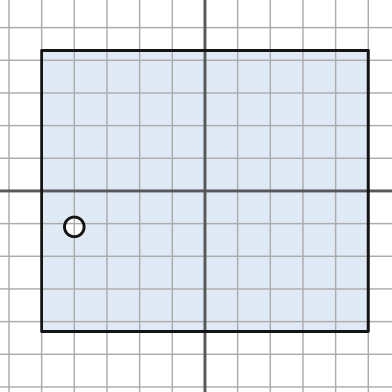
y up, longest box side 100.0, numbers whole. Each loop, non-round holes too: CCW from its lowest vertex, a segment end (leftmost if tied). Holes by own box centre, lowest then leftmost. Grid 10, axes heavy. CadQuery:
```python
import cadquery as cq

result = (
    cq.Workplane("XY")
    .moveTo(-50.0, -43.0)
    .lineTo(50.0, -43.0)
    .lineTo(50.0, 43.0)
    .lineTo(-50.0, 43.0)
    .close()
    .moveTo(-40.0, -11.0)
    .circle(3.0)
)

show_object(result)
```